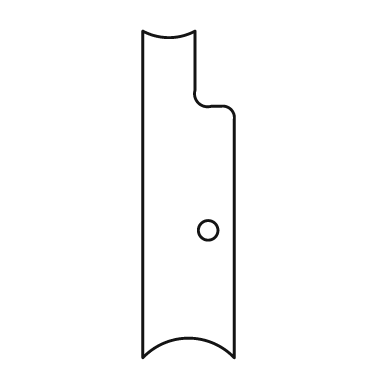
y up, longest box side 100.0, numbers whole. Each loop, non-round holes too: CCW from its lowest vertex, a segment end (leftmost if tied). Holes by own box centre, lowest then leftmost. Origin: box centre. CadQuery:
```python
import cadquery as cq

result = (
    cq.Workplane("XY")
    .moveTo(-14.0, -50.0)
    .threePointArc((0.0, -44.0), (14.0, -50.0))
    .lineTo(14.0, 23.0)
    .threePointArc((13.0, 26.0), (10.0, 27.0))
    .lineTo(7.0, 27.0)
    .threePointArc((3.0, 28.0), (2.0, 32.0))
    .lineTo(2.0, 50.0)
    .threePointArc((-6.0, 48.0), (-14.0, 50.0))
    .close()
    .moveTo(6.0, -11.0)
    .circle(3.0)
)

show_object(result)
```